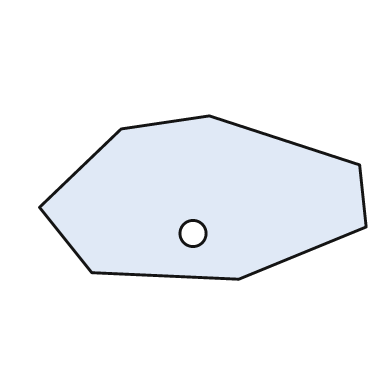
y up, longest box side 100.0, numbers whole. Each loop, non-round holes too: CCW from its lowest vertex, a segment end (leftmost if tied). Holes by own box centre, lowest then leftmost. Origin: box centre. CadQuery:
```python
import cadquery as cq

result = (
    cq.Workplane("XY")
    .moveTo(11.0, -25.0)
    .lineTo(50.0, -9.0)
    .lineTo(48.0, 10.0)
    .lineTo(2.0, 25.0)
    .lineTo(-25.0, 21.0)
    .lineTo(-50.0, -3.0)
    .lineTo(-34.0, -23.0)
    .close()
    .moveTo(-3.0, -11.0)
    .circle(4.0)
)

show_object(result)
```